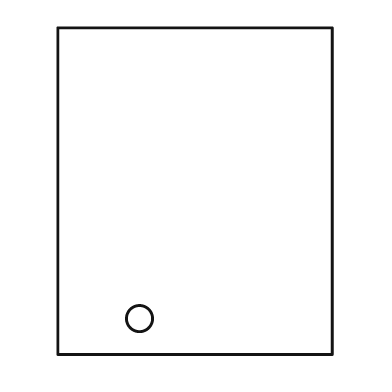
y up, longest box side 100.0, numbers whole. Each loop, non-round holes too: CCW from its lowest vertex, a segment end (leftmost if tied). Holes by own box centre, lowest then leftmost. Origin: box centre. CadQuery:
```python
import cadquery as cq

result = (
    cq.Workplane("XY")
    .moveTo(-42.0, -50.0)
    .lineTo(42.0, -50.0)
    .lineTo(42.0, 50.0)
    .lineTo(-42.0, 50.0)
    .close()
    .moveTo(-17.0, -39.0)
    .circle(4.0)
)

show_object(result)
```